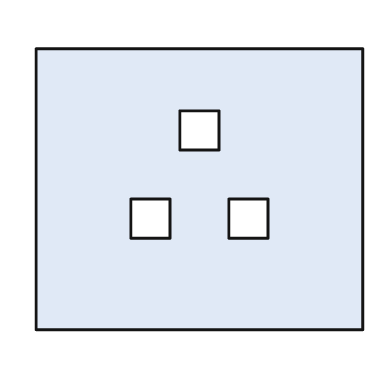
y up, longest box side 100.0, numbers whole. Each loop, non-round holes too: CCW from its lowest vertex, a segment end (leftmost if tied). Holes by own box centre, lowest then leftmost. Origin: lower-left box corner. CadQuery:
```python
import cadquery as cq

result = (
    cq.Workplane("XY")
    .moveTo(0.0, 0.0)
    .lineTo(100.0, 0.0)
    .lineTo(100.0, 86.0)
    .lineTo(0.0, 86.0)
    .close()
    .moveTo(29.0, 28.0)
    .lineTo(41.0, 28.0)
    .lineTo(41.0, 40.0)
    .lineTo(29.0, 40.0)
    .close()
    .moveTo(59.0, 28.0)
    .lineTo(71.0, 28.0)
    .lineTo(71.0, 40.0)
    .lineTo(59.0, 40.0)
    .close()
    .moveTo(44.0, 55.0)
    .lineTo(56.0, 55.0)
    .lineTo(56.0, 67.0)
    .lineTo(44.0, 67.0)
    .close()
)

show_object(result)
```